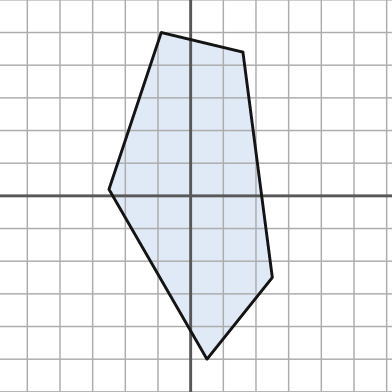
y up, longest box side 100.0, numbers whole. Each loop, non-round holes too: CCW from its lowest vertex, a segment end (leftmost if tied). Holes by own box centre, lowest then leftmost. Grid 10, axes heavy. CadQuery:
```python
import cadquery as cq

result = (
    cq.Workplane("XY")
    .moveTo(5.0, -50.0)
    .lineTo(25.0, -25.0)
    .lineTo(16.0, 44.0)
    .lineTo(-9.0, 50.0)
    .lineTo(-25.0, 2.0)
    .close()
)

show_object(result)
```